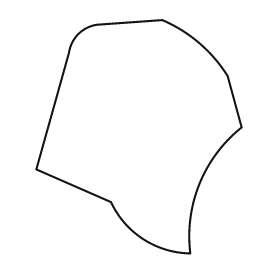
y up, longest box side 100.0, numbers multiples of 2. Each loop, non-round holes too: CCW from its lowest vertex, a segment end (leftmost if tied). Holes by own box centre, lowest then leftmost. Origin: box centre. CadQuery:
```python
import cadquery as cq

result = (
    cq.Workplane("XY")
    .moveTo(22.0, -50.0)
    .threePointArc((26.0, -20.0), (44.0, 4.0))
    .lineTo(38.0, 26.0)
    .threePointArc((26.0, 40.0), (10.0, 50.0))
    .lineTo(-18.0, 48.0)
    .threePointArc((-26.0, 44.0), (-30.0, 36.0))
    .lineTo(-44.0, -14.0)
    .lineTo(-12.0, -28.0)
    .threePointArc((2.0, -44.0), (22.0, -50.0))
    .close()
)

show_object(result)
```